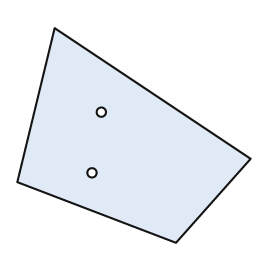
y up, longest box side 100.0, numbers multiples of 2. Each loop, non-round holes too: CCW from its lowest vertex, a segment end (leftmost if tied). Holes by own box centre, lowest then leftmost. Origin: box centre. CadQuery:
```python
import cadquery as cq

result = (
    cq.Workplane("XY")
    .moveTo(18.0, -46.0)
    .lineTo(50.0, -10.0)
    .lineTo(-34.0, 46.0)
    .lineTo(-50.0, -20.0)
    .close()
    .moveTo(-18.0, -16.0)
    .circle(2.0)
    .moveTo(-14.0, 10.0)
    .circle(2.0)
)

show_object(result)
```